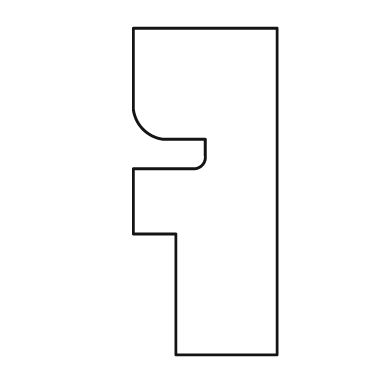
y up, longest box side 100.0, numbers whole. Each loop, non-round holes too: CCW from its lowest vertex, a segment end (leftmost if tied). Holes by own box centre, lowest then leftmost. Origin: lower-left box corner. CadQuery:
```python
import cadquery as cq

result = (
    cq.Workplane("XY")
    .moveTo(13.0, 0.0)
    .lineTo(44.0, 0.0)
    .lineTo(44.0, 100.0)
    .lineTo(0.0, 100.0)
    .lineTo(0.0, 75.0)
    .threePointArc((3.0, 69.0), (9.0, 66.0))
    .lineTo(22.0, 66.0)
    .lineTo(22.0, 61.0)
    .threePointArc((21.0, 58.0), (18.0, 57.0))
    .lineTo(0.0, 57.0)
    .lineTo(0.0, 37.0)
    .lineTo(13.0, 37.0)
    .close()
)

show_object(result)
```